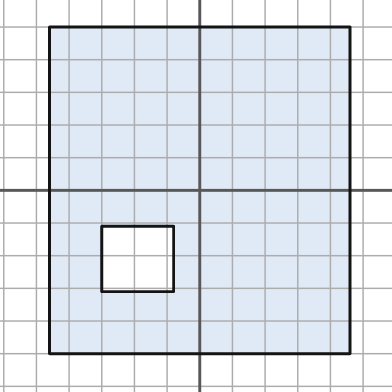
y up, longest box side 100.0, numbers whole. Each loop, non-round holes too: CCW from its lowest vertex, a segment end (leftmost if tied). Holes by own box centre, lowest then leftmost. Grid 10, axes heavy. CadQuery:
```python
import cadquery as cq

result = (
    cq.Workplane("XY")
    .moveTo(-46.0, -50.0)
    .lineTo(46.0, -50.0)
    .lineTo(46.0, 50.0)
    .lineTo(-46.0, 50.0)
    .close()
    .moveTo(-30.0, -31.0)
    .lineTo(-8.0, -31.0)
    .lineTo(-8.0, -11.0)
    .lineTo(-30.0, -11.0)
    .close()
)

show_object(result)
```